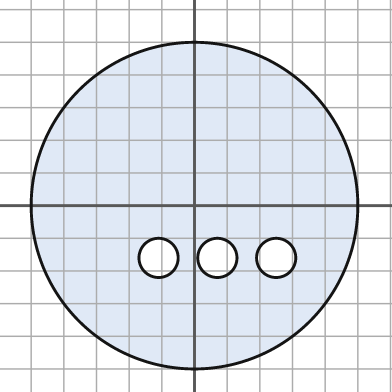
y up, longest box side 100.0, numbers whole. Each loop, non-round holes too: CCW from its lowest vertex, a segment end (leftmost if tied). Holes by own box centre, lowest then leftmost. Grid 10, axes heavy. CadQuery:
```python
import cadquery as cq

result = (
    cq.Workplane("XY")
    .moveTo(0.0, 0.0)
    .circle(50.0)
    .moveTo(-11.0, -16.0)
    .circle(6.0)
    .moveTo(7.0, -16.0)
    .circle(6.0)
    .moveTo(25.0, -16.0)
    .circle(6.0)
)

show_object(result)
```